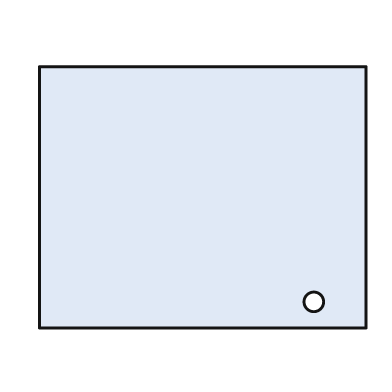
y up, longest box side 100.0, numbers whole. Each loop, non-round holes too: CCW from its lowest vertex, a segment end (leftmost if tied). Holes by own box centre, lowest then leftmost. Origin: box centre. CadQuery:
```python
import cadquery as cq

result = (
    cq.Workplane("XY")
    .moveTo(-50.0, -40.0)
    .lineTo(50.0, -40.0)
    .lineTo(50.0, 40.0)
    .lineTo(-50.0, 40.0)
    .close()
    .moveTo(34.0, -32.0)
    .circle(3.0)
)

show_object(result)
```